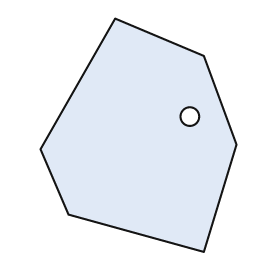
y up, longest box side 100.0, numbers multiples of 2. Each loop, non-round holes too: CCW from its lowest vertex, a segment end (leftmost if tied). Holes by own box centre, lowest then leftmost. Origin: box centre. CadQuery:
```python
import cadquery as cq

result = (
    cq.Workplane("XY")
    .moveTo(28.0, -50.0)
    .lineTo(42.0, -4.0)
    .lineTo(28.0, 34.0)
    .lineTo(-10.0, 50.0)
    .lineTo(-42.0, -6.0)
    .lineTo(-30.0, -34.0)
    .close()
    .moveTo(22.0, 8.0)
    .circle(4.0)
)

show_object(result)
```